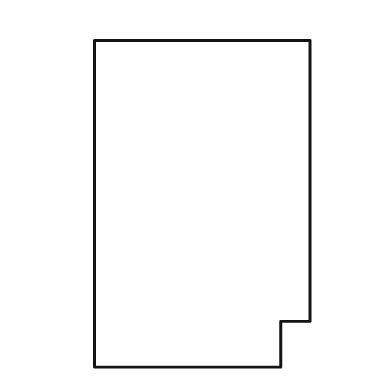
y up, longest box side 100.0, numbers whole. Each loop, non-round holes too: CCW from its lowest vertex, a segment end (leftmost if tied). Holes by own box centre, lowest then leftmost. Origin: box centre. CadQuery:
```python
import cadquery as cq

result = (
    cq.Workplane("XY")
    .moveTo(-33.0, -50.0)
    .lineTo(24.0, -50.0)
    .lineTo(24.0, -36.0)
    .lineTo(33.0, -36.0)
    .lineTo(33.0, 50.0)
    .lineTo(-33.0, 50.0)
    .close()
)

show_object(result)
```